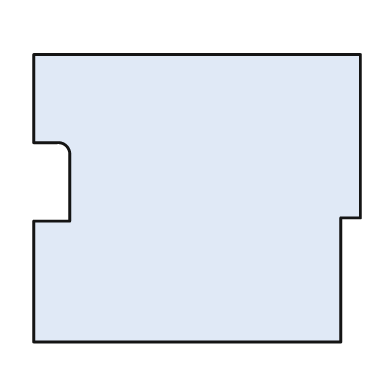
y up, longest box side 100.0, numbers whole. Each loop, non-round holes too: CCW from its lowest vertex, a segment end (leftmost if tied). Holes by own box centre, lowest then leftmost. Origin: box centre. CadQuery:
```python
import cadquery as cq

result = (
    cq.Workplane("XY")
    .moveTo(-50.0, -44.0)
    .lineTo(44.0, -44.0)
    .lineTo(44.0, -6.0)
    .lineTo(50.0, -6.0)
    .lineTo(50.0, 44.0)
    .lineTo(-50.0, 44.0)
    .lineTo(-50.0, 17.0)
    .lineTo(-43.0, 17.0)
    .threePointArc((-40.0, 16.0), (-39.0, 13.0))
    .lineTo(-39.0, -7.0)
    .lineTo(-50.0, -7.0)
    .close()
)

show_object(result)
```